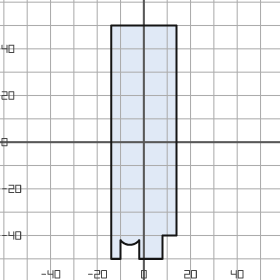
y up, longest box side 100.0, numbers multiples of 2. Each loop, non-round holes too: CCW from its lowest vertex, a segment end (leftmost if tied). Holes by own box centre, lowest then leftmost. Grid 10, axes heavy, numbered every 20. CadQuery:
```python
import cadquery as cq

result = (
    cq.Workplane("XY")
    .moveTo(-14.0, -50.0)
    .lineTo(-10.0, -50.0)
    .lineTo(-10.0, -42.0)
    .threePointArc((-6.0, -44.0), (-2.0, -42.0))
    .lineTo(-2.0, -50.0)
    .lineTo(8.0, -50.0)
    .lineTo(8.0, -40.0)
    .lineTo(14.0, -40.0)
    .lineTo(14.0, 50.0)
    .lineTo(-14.0, 50.0)
    .close()
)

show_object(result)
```